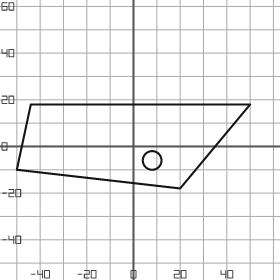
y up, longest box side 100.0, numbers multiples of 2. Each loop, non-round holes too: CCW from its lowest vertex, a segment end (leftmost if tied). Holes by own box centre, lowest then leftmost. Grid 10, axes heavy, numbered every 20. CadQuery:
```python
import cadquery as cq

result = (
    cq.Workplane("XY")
    .moveTo(20.0, -18.0)
    .lineTo(50.0, 18.0)
    .lineTo(-44.0, 18.0)
    .lineTo(-50.0, -10.0)
    .close()
    .moveTo(8.0, -6.0)
    .circle(4.0)
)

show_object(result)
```